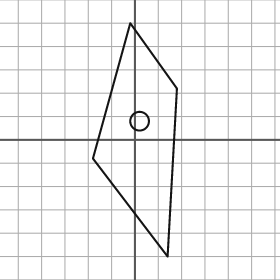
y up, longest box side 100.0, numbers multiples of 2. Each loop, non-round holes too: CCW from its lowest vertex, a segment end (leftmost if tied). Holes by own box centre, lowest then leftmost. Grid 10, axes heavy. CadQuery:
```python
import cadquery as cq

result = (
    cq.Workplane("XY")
    .moveTo(14.0, -50.0)
    .lineTo(18.0, 22.0)
    .lineTo(-2.0, 50.0)
    .lineTo(-18.0, -8.0)
    .close()
    .moveTo(2.0, 8.0)
    .circle(4.0)
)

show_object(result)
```